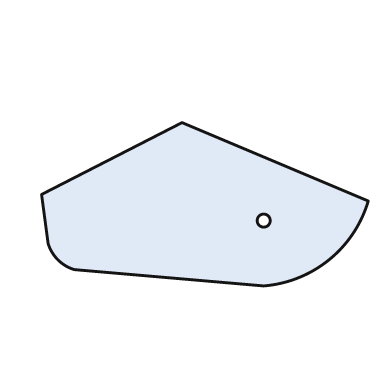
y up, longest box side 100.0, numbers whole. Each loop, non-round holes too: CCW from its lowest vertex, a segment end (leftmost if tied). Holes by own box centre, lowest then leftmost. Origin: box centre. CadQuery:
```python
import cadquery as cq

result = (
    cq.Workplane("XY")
    .moveTo(18.0, -25.0)
    .threePointArc((38.0, -17.0), (50.0, 1.0))
    .lineTo(-7.0, 25.0)
    .lineTo(-50.0, 3.0)
    .lineTo(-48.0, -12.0)
    .threePointArc((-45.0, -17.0), (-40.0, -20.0))
    .close()
    .moveTo(18.0, -5.0)
    .circle(2.0)
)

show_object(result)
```